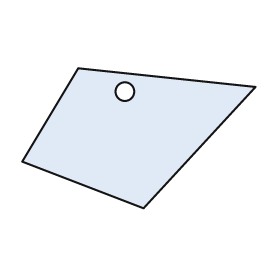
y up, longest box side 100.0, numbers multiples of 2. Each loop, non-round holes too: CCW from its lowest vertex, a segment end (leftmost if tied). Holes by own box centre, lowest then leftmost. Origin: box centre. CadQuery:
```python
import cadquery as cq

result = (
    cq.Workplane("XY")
    .moveTo(2.0, -30.0)
    .lineTo(50.0, 22.0)
    .lineTo(-26.0, 30.0)
    .lineTo(-50.0, -10.0)
    .close()
    .moveTo(-6.0, 20.0)
    .circle(4.0)
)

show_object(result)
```